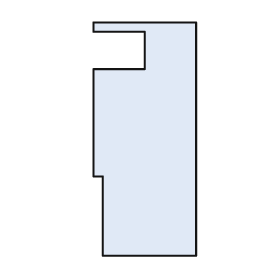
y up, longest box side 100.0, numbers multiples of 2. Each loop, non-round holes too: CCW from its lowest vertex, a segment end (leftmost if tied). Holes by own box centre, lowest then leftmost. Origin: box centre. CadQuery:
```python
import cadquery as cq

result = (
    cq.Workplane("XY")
    .moveTo(-18.0, -50.0)
    .lineTo(22.0, -50.0)
    .lineTo(22.0, 50.0)
    .lineTo(-22.0, 50.0)
    .lineTo(-22.0, 46.0)
    .lineTo(0.0, 46.0)
    .lineTo(0.0, 30.0)
    .lineTo(-22.0, 30.0)
    .lineTo(-22.0, -16.0)
    .lineTo(-18.0, -16.0)
    .close()
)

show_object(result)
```